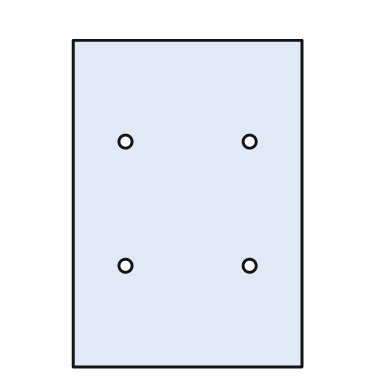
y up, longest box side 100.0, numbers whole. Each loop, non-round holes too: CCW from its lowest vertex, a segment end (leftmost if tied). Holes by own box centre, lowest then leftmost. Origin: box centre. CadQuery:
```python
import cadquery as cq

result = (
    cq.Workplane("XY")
    .moveTo(-35.0, -50.0)
    .lineTo(35.0, -50.0)
    .lineTo(35.0, 50.0)
    .lineTo(-35.0, 50.0)
    .close()
    .moveTo(-19.0, -19.0)
    .circle(2.0)
    .moveTo(19.0, -19.0)
    .circle(2.0)
    .moveTo(-19.0, 19.0)
    .circle(2.0)
    .moveTo(19.0, 19.0)
    .circle(2.0)
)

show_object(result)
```